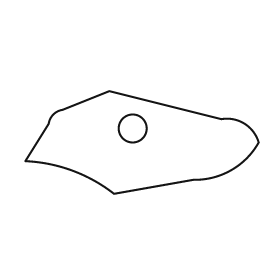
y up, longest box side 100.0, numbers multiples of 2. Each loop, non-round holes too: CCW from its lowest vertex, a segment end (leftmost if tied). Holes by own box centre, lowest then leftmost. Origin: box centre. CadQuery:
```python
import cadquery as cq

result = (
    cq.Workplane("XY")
    .moveTo(-12.0, -22.0)
    .lineTo(22.0, -16.0)
    .threePointArc((38.0, -12.0), (50.0, 0.0))
    .threePointArc((44.0, 8.0), (34.0, 10.0))
    .lineTo(-14.0, 22.0)
    .lineTo(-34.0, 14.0)
    .threePointArc((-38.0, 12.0), (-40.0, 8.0))
    .lineTo(-50.0, -8.0)
    .threePointArc((-30.0, -12.0), (-12.0, -22.0))
    .close()
    .moveTo(-4.0, 6.0)
    .circle(6.0)
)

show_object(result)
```